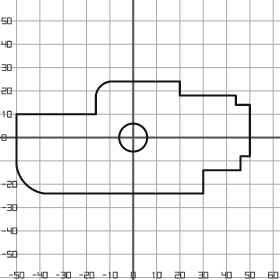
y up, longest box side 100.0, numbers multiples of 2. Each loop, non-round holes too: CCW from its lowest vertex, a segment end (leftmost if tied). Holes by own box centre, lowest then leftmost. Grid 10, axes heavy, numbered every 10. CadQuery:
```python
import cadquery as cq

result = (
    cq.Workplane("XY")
    .moveTo(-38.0, -24.0)
    .lineTo(30.0, -24.0)
    .lineTo(30.0, -14.0)
    .lineTo(46.0, -14.0)
    .lineTo(46.0, -8.0)
    .lineTo(50.0, -8.0)
    .lineTo(50.0, 14.0)
    .lineTo(44.0, 14.0)
    .lineTo(44.0, 18.0)
    .lineTo(20.0, 18.0)
    .lineTo(20.0, 24.0)
    .lineTo(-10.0, 24.0)
    .threePointArc((-14.0, 22.0), (-16.0, 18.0))
    .lineTo(-16.0, 10.0)
    .lineTo(-50.0, 10.0)
    .lineTo(-50.0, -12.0)
    .threePointArc((-46.0, -20.0), (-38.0, -24.0))
    .close()
    .moveTo(0.0, 0.0)
    .circle(6.0)
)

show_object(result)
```